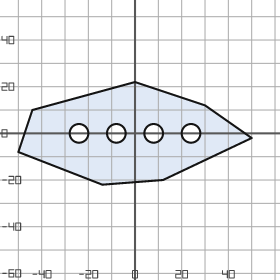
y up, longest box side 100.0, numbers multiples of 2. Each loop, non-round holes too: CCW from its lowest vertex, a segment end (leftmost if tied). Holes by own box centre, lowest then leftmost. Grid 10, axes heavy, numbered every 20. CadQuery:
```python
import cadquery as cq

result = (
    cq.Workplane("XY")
    .moveTo(-14.0, -22.0)
    .lineTo(12.0, -20.0)
    .lineTo(50.0, -2.0)
    .lineTo(30.0, 12.0)
    .lineTo(0.0, 22.0)
    .lineTo(-44.0, 10.0)
    .lineTo(-50.0, -8.0)
    .close()
    .moveTo(-24.0, 0.0)
    .circle(4.0)
    .moveTo(-8.0, 0.0)
    .circle(4.0)
    .moveTo(8.0, 0.0)
    .circle(4.0)
    .moveTo(24.0, 0.0)
    .circle(4.0)
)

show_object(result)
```